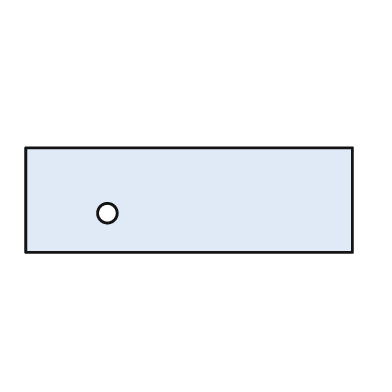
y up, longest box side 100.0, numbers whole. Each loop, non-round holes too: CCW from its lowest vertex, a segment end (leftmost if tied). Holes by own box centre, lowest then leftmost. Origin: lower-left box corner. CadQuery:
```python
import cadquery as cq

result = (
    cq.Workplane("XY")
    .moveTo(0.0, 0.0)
    .lineTo(100.0, 0.0)
    .lineTo(100.0, 32.0)
    .lineTo(0.0, 32.0)
    .close()
    .moveTo(25.0, 12.0)
    .circle(3.0)
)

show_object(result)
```